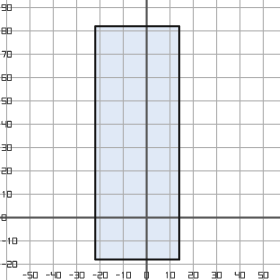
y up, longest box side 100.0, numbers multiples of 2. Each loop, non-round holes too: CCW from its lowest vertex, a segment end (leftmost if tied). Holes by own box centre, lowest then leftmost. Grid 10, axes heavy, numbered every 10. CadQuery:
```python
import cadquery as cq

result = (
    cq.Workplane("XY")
    .moveTo(-22.0, -18.0)
    .lineTo(14.0, -18.0)
    .lineTo(14.0, 82.0)
    .lineTo(-22.0, 82.0)
    .close()
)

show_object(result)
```